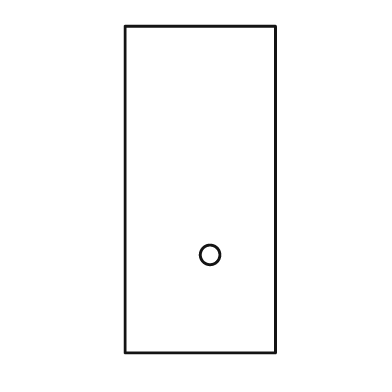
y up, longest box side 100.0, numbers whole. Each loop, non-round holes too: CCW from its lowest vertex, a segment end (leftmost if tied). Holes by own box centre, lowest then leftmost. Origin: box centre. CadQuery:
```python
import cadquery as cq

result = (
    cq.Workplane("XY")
    .moveTo(-23.0, -50.0)
    .lineTo(23.0, -50.0)
    .lineTo(23.0, 50.0)
    .lineTo(-23.0, 50.0)
    .close()
    .moveTo(3.0, -20.0)
    .circle(3.0)
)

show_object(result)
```